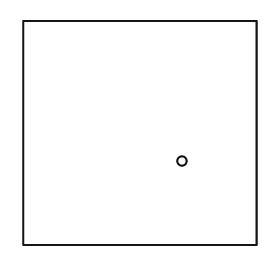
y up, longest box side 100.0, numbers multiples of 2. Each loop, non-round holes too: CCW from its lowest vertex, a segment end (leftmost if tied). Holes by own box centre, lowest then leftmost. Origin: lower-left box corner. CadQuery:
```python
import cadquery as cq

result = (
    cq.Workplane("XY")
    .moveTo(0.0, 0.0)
    .lineTo(100.0, 0.0)
    .lineTo(100.0, 96.0)
    .lineTo(0.0, 96.0)
    .close()
    .moveTo(68.0, 36.0)
    .circle(2.0)
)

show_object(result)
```